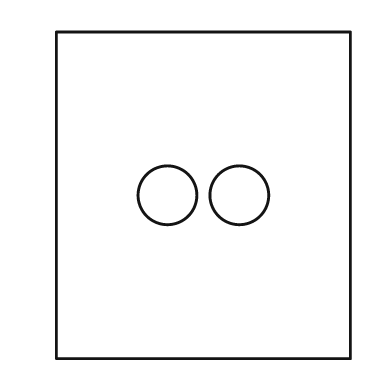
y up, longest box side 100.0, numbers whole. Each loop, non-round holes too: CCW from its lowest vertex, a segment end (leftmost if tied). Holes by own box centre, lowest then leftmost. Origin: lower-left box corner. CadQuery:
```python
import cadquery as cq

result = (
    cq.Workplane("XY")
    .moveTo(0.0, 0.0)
    .lineTo(90.0, 0.0)
    .lineTo(90.0, 100.0)
    .lineTo(0.0, 100.0)
    .close()
    .moveTo(34.0, 50.0)
    .circle(9.0)
    .moveTo(56.0, 50.0)
    .circle(9.0)
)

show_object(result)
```